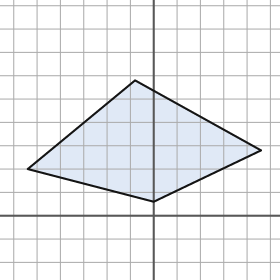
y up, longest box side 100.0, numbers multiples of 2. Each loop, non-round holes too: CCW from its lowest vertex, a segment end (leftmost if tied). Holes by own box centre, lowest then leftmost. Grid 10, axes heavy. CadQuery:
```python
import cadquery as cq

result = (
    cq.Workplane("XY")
    .moveTo(0.0, 6.0)
    .lineTo(46.0, 28.0)
    .lineTo(-8.0, 58.0)
    .lineTo(-54.0, 20.0)
    .close()
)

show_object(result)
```